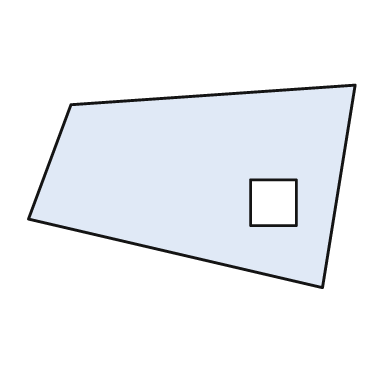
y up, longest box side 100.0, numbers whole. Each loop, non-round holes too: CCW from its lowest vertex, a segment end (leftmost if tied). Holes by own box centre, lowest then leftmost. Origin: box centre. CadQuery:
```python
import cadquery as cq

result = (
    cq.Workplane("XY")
    .moveTo(40.0, -31.0)
    .lineTo(50.0, 31.0)
    .lineTo(-37.0, 25.0)
    .lineTo(-50.0, -10.0)
    .close()
    .moveTo(18.0, -12.0)
    .lineTo(32.0, -12.0)
    .lineTo(32.0, 2.0)
    .lineTo(18.0, 2.0)
    .close()
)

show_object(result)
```